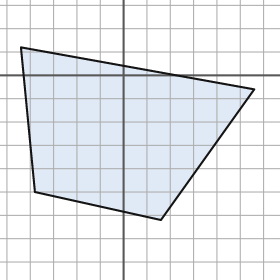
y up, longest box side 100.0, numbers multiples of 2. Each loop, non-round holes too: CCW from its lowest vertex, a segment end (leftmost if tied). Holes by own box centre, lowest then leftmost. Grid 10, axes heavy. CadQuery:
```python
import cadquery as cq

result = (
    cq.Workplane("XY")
    .moveTo(16.0, -62.0)
    .lineTo(56.0, -6.0)
    .lineTo(-44.0, 12.0)
    .lineTo(-38.0, -50.0)
    .close()
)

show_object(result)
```